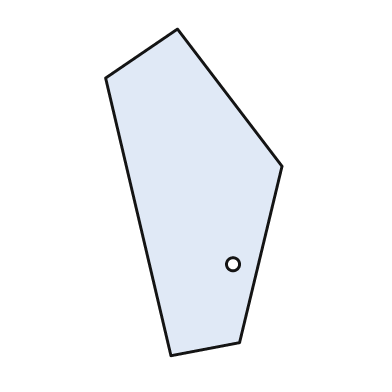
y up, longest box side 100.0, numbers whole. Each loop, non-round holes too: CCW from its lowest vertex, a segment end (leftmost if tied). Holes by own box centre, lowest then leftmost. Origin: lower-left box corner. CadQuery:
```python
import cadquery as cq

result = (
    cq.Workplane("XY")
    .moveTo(20.0, 0.0)
    .lineTo(41.0, 4.0)
    .lineTo(54.0, 58.0)
    .lineTo(22.0, 100.0)
    .lineTo(0.0, 85.0)
    .close()
    .moveTo(39.0, 28.0)
    .circle(2.0)
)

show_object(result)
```